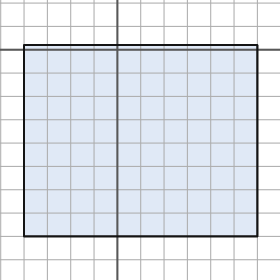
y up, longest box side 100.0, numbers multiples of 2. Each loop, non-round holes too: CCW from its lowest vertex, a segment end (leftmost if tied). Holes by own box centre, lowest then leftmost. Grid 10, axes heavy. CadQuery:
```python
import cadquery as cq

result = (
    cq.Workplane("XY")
    .moveTo(-40.0, -80.0)
    .lineTo(60.0, -80.0)
    .lineTo(60.0, 2.0)
    .lineTo(-40.0, 2.0)
    .close()
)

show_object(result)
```